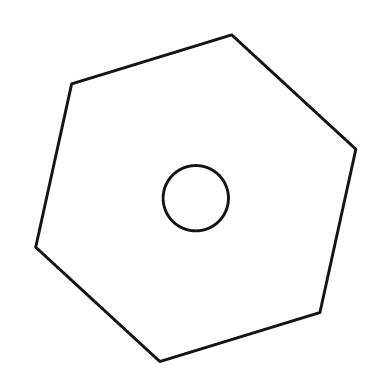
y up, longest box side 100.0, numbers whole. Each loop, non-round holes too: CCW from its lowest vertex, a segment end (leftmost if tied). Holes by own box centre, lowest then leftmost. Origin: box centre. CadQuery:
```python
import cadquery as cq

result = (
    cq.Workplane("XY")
    .moveTo(-11.0, -50.0)
    .lineTo(38.0, -35.0)
    .lineTo(49.0, 15.0)
    .lineTo(11.0, 50.0)
    .lineTo(-38.0, 35.0)
    .lineTo(-49.0, -15.0)
    .close()
    .moveTo(0.0, 0.0)
    .circle(10.0)
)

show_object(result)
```